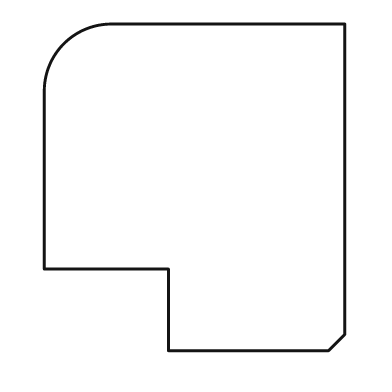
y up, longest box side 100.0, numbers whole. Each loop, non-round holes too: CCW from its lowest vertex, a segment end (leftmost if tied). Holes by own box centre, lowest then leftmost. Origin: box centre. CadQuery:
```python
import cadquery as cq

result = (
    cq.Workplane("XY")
    .moveTo(-8.0, -50.0)
    .lineTo(41.0, -50.0)
    .lineTo(46.0, -45.0)
    .lineTo(46.0, 50.0)
    .lineTo(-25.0, 50.0)
    .threePointArc((-40.0, 44.0), (-46.0, 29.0))
    .lineTo(-46.0, -25.0)
    .lineTo(-8.0, -25.0)
    .close()
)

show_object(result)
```